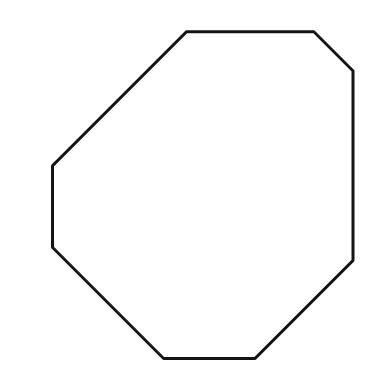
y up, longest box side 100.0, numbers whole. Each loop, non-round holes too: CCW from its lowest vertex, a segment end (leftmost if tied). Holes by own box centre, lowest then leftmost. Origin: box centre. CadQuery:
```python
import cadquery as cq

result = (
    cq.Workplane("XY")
    .moveTo(-12.0, -50.0)
    .lineTo(16.0, -50.0)
    .lineTo(46.0, -20.0)
    .lineTo(46.0, 38.0)
    .lineTo(34.0, 50.0)
    .lineTo(-5.0, 50.0)
    .lineTo(-46.0, 9.0)
    .lineTo(-46.0, -16.0)
    .close()
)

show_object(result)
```